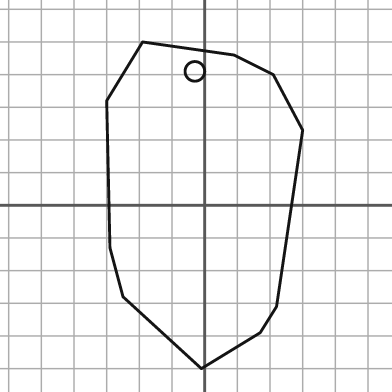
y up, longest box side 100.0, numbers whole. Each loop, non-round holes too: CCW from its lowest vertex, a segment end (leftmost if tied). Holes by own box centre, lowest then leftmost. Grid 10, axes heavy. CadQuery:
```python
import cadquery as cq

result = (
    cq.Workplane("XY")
    .moveTo(-1.0, -50.0)
    .lineTo(17.0, -39.0)
    .lineTo(22.0, -31.0)
    .lineTo(30.0, 23.0)
    .lineTo(21.0, 40.0)
    .lineTo(9.0, 46.0)
    .lineTo(-19.0, 50.0)
    .lineTo(-30.0, 32.0)
    .lineTo(-29.0, -13.0)
    .lineTo(-25.0, -28.0)
    .close()
    .moveTo(-3.0, 41.0)
    .circle(3.0)
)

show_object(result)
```